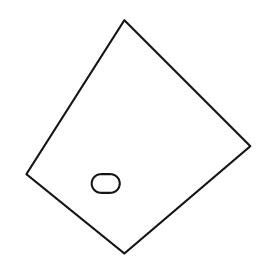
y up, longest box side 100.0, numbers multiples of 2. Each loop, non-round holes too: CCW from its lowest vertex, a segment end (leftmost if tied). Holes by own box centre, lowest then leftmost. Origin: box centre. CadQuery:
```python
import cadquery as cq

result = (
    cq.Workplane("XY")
    .moveTo(-6.0, -50.0)
    .lineTo(48.0, -4.0)
    .lineTo(-6.0, 50.0)
    .lineTo(-48.0, -16.0)
    .close()
    .moveTo(-16.0, -24.0)
    .lineTo(-12.0, -24.0)
    .threePointArc((-8.0, -20.0), (-12.0, -16.0))
    .lineTo(-16.0, -16.0)
    .threePointArc((-20.0, -20.0), (-16.0, -24.0))
    .close()
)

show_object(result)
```